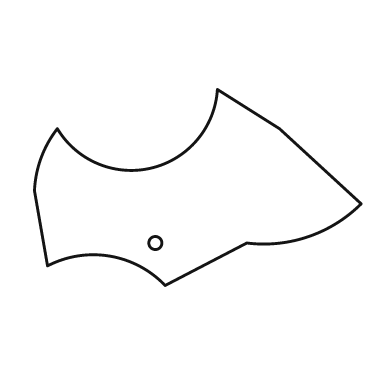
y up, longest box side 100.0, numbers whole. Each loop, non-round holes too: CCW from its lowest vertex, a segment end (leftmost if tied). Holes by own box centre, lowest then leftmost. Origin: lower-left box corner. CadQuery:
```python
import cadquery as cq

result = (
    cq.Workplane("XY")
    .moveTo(40.0, 0.0)
    .lineTo(65.0, 13.0)
    .threePointArc((84.0, 15.0), (100.0, 25.0))
    .lineTo(75.0, 48.0)
    .lineTo(56.0, 60.0)
    .threePointArc((36.0, 36.0), (7.0, 48.0))
    .threePointArc((2.0, 39.0), (0.0, 29.0))
    .lineTo(4.0, 6.0)
    .threePointArc((23.0, 9.0), (40.0, 0.0))
    .close()
    .moveTo(37.0, 13.0)
    .circle(2.0)
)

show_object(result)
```